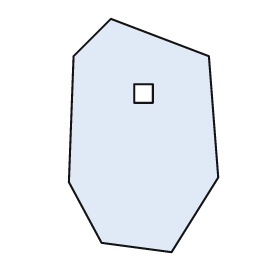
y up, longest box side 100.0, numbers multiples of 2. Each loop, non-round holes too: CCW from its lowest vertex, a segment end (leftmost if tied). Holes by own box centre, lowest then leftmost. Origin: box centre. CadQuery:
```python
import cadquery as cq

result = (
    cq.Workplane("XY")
    .moveTo(12.0, -50.0)
    .lineTo(32.0, -18.0)
    .lineTo(28.0, 34.0)
    .lineTo(-14.0, 50.0)
    .lineTo(-30.0, 34.0)
    .lineTo(-32.0, -20.0)
    .lineTo(-18.0, -46.0)
    .close()
    .moveTo(-4.0, 14.0)
    .lineTo(4.0, 14.0)
    .lineTo(4.0, 22.0)
    .lineTo(-4.0, 22.0)
    .close()
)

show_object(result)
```